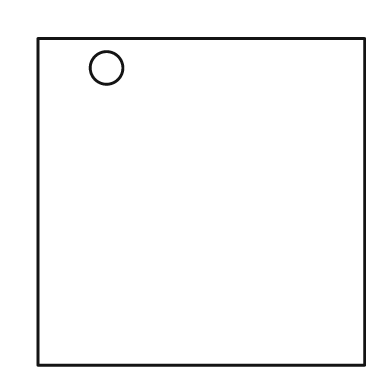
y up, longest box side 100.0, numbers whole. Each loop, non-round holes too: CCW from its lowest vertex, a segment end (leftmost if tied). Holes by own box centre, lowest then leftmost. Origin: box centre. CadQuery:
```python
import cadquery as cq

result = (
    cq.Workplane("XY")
    .moveTo(-50.0, -50.0)
    .lineTo(50.0, -50.0)
    .lineTo(50.0, 50.0)
    .lineTo(-50.0, 50.0)
    .close()
    .moveTo(-29.0, 41.0)
    .circle(5.0)
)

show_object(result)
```